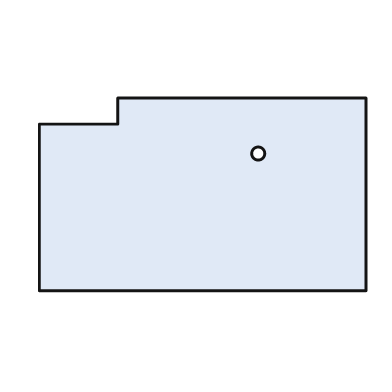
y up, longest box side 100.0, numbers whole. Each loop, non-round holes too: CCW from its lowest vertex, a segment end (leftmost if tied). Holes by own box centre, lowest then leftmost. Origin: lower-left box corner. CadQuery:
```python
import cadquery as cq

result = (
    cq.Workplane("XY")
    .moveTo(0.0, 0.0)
    .lineTo(100.0, 0.0)
    .lineTo(100.0, 59.0)
    .lineTo(24.0, 59.0)
    .lineTo(24.0, 51.0)
    .lineTo(0.0, 51.0)
    .close()
    .moveTo(67.0, 42.0)
    .circle(2.0)
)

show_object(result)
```